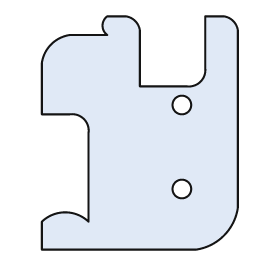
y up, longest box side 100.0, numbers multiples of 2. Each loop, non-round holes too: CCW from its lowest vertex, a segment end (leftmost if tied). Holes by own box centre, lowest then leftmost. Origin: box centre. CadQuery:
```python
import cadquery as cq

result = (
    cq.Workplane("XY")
    .moveTo(-42.0, -50.0)
    .lineTo(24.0, -50.0)
    .threePointArc((36.0, -44.0), (42.0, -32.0))
    .lineTo(42.0, 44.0)
    .threePointArc((40.0, 48.0), (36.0, 50.0))
    .lineTo(28.0, 50.0)
    .lineTo(28.0, 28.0)
    .threePointArc((26.0, 22.0), (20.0, 20.0))
    .lineTo(0.0, 20.0)
    .lineTo(0.0, 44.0)
    .threePointArc((-2.0, 48.0), (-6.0, 50.0))
    .lineTo(-14.0, 50.0)
    .threePointArc((-16.0, 46.0), (-14.0, 42.0))
    .lineTo(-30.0, 42.0)
    .threePointArc((-38.0, 38.0), (-42.0, 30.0))
    .lineTo(-42.0, 8.0)
    .lineTo(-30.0, 8.0)
    .threePointArc((-24.0, 6.0), (-22.0, 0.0))
    .lineTo(-22.0, -38.0)
    .threePointArc((-32.0, -34.0), (-42.0, -38.0))
    .close()
    .moveTo(18.0, -24.0)
    .circle(4.0)
    .moveTo(18.0, 12.0)
    .circle(4.0)
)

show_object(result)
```